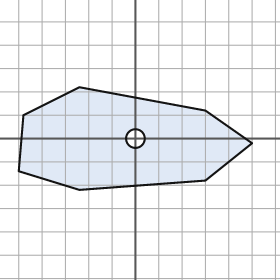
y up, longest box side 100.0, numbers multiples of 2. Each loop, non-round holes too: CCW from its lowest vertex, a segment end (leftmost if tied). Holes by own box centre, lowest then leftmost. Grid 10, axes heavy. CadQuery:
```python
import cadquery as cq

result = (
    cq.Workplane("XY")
    .moveTo(-24.0, -22.0)
    .lineTo(30.0, -18.0)
    .lineTo(50.0, -2.0)
    .lineTo(30.0, 12.0)
    .lineTo(-24.0, 22.0)
    .lineTo(-48.0, 10.0)
    .lineTo(-50.0, -14.0)
    .close()
    .moveTo(0.0, 0.0)
    .circle(4.0)
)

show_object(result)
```